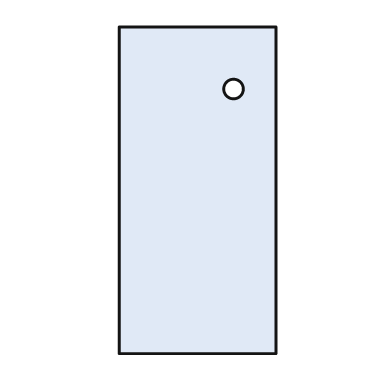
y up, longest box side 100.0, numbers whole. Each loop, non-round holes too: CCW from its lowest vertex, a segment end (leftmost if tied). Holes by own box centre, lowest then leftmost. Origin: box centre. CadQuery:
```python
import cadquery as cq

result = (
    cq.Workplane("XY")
    .moveTo(-24.0, -50.0)
    .lineTo(24.0, -50.0)
    .lineTo(24.0, 50.0)
    .lineTo(-24.0, 50.0)
    .close()
    .moveTo(11.0, 31.0)
    .circle(3.0)
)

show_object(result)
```